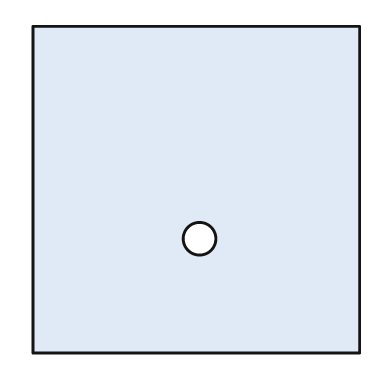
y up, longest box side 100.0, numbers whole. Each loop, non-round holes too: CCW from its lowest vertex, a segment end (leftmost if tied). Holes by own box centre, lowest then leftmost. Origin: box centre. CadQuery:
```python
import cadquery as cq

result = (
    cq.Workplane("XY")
    .moveTo(-50.0, -50.0)
    .lineTo(50.0, -50.0)
    .lineTo(50.0, 50.0)
    .lineTo(-50.0, 50.0)
    .close()
    .moveTo(1.0, -15.0)
    .circle(5.0)
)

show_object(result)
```